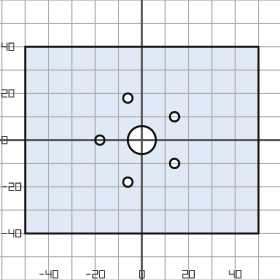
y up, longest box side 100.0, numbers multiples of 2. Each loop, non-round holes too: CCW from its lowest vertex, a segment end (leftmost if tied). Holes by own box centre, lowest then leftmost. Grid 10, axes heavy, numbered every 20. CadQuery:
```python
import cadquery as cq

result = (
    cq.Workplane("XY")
    .moveTo(-50.0, -40.0)
    .lineTo(50.0, -40.0)
    .lineTo(50.0, 40.0)
    .lineTo(-50.0, 40.0)
    .close()
    .moveTo(-6.0, -18.0)
    .circle(2.0)
    .moveTo(14.0, -10.0)
    .circle(2.0)
    .moveTo(-18.0, 0.0)
    .circle(2.0)
    .moveTo(0.0, 0.0)
    .circle(6.0)
    .moveTo(14.0, 10.0)
    .circle(2.0)
    .moveTo(-6.0, 18.0)
    .circle(2.0)
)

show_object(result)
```